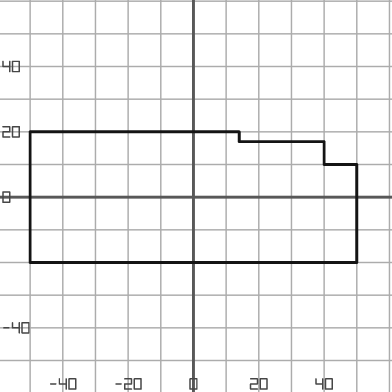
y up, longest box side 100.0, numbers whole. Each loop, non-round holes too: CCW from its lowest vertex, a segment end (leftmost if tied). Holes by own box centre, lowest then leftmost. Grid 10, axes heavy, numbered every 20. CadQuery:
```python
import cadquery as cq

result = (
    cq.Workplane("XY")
    .moveTo(-50.0, -20.0)
    .lineTo(50.0, -20.0)
    .lineTo(50.0, 10.0)
    .lineTo(40.0, 10.0)
    .lineTo(40.0, 17.0)
    .lineTo(14.0, 17.0)
    .lineTo(14.0, 20.0)
    .lineTo(-50.0, 20.0)
    .close()
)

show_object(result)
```